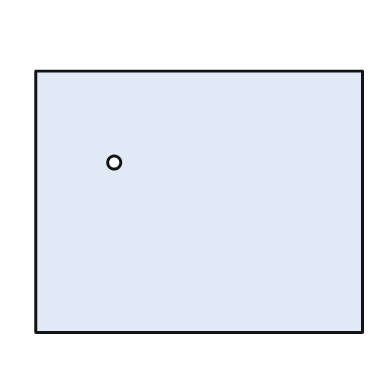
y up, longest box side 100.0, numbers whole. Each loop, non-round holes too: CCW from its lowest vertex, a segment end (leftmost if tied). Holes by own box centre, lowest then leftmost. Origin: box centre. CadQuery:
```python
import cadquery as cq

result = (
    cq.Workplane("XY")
    .moveTo(-50.0, -40.0)
    .lineTo(50.0, -40.0)
    .lineTo(50.0, 40.0)
    .lineTo(-50.0, 40.0)
    .close()
    .moveTo(-26.0, 12.0)
    .circle(2.0)
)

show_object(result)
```